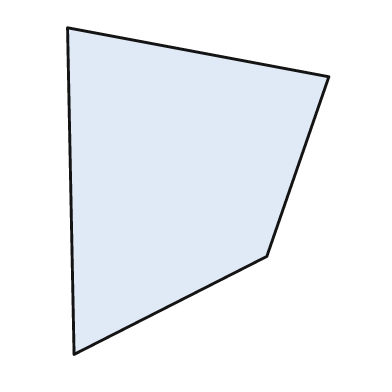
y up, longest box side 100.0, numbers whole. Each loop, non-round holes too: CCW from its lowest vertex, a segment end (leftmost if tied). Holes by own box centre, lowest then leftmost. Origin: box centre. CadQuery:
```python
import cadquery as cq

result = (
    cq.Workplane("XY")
    .moveTo(-38.0, -50.0)
    .lineTo(21.0, -20.0)
    .lineTo(40.0, 35.0)
    .lineTo(-40.0, 50.0)
    .close()
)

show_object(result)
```